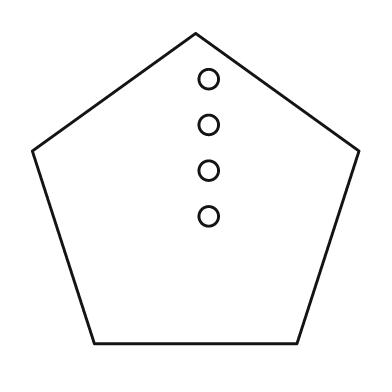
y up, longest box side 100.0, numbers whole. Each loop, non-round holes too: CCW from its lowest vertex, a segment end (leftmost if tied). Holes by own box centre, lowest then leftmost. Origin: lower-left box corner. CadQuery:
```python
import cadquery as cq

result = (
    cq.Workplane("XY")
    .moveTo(19.0, 0.0)
    .lineTo(81.0, 0.0)
    .lineTo(100.0, 59.0)
    .lineTo(50.0, 95.0)
    .lineTo(0.0, 59.0)
    .close()
    .moveTo(54.0, 39.0)
    .circle(3.0)
    .moveTo(54.0, 53.0)
    .circle(3.0)
    .moveTo(54.0, 67.0)
    .circle(3.0)
    .moveTo(54.0, 81.0)
    .circle(3.0)
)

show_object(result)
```